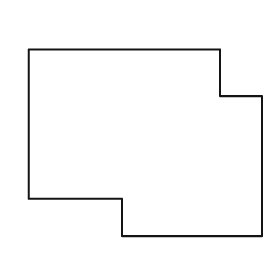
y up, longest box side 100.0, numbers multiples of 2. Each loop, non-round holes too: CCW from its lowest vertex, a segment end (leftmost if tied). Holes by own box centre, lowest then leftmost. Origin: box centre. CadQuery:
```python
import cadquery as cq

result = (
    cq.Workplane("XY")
    .moveTo(-10.0, -40.0)
    .lineTo(50.0, -40.0)
    .lineTo(50.0, 20.0)
    .lineTo(32.0, 20.0)
    .lineTo(32.0, 40.0)
    .lineTo(-50.0, 40.0)
    .lineTo(-50.0, -24.0)
    .lineTo(-10.0, -24.0)
    .close()
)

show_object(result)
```